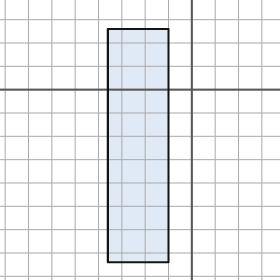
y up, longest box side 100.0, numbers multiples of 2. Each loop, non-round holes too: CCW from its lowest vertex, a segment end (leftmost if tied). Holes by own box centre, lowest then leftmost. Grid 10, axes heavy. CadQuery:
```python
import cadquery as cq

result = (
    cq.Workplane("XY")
    .moveTo(-36.0, -74.0)
    .lineTo(-10.0, -74.0)
    .lineTo(-10.0, 26.0)
    .lineTo(-36.0, 26.0)
    .close()
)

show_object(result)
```